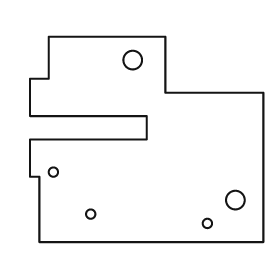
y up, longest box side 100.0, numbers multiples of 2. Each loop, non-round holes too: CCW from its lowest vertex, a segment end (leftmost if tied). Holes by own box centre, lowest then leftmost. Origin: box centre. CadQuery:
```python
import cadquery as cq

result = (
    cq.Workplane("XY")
    .moveTo(-46.0, -44.0)
    .lineTo(50.0, -44.0)
    .lineTo(50.0, 20.0)
    .lineTo(8.0, 20.0)
    .lineTo(8.0, 44.0)
    .lineTo(-42.0, 44.0)
    .lineTo(-42.0, 26.0)
    .lineTo(-50.0, 26.0)
    .lineTo(-50.0, 10.0)
    .lineTo(0.0, 10.0)
    .lineTo(0.0, 0.0)
    .lineTo(-50.0, 0.0)
    .lineTo(-50.0, -16.0)
    .lineTo(-46.0, -16.0)
    .close()
    .moveTo(26.0, -36.0)
    .circle(2.0)
    .moveTo(-24.0, -32.0)
    .circle(2.0)
    .moveTo(38.0, -26.0)
    .circle(4.0)
    .moveTo(-40.0, -14.0)
    .circle(2.0)
    .moveTo(-6.0, 34.0)
    .circle(4.0)
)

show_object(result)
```